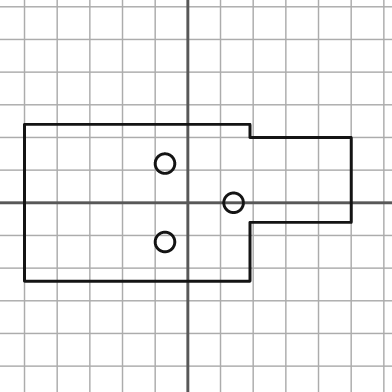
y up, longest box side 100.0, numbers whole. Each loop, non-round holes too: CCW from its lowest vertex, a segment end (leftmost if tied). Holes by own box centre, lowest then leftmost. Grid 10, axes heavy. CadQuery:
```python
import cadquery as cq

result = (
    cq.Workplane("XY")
    .moveTo(-50.0, -24.0)
    .lineTo(19.0, -24.0)
    .lineTo(19.0, -6.0)
    .lineTo(50.0, -6.0)
    .lineTo(50.0, 20.0)
    .lineTo(19.0, 20.0)
    .lineTo(19.0, 24.0)
    .lineTo(-50.0, 24.0)
    .close()
    .moveTo(-7.0, -12.0)
    .circle(3.0)
    .moveTo(14.0, 0.0)
    .circle(3.0)
    .moveTo(-7.0, 12.0)
    .circle(3.0)
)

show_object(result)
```